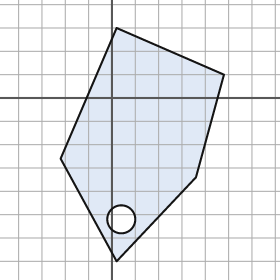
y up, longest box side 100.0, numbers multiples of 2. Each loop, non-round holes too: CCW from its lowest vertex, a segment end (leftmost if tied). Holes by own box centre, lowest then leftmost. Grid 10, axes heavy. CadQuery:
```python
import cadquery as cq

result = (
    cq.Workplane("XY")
    .moveTo(2.0, -70.0)
    .lineTo(36.0, -34.0)
    .lineTo(48.0, 10.0)
    .lineTo(2.0, 30.0)
    .lineTo(-22.0, -26.0)
    .close()
    .moveTo(4.0, -52.0)
    .circle(6.0)
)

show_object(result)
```